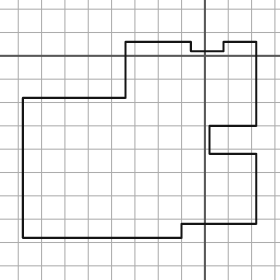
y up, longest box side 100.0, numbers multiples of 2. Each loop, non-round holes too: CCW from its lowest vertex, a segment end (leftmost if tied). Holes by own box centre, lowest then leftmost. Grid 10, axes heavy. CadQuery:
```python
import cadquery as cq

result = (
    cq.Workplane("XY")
    .moveTo(-78.0, -78.0)
    .lineTo(-10.0, -78.0)
    .lineTo(-10.0, -72.0)
    .lineTo(22.0, -72.0)
    .lineTo(22.0, -42.0)
    .lineTo(2.0, -42.0)
    .lineTo(2.0, -30.0)
    .lineTo(22.0, -30.0)
    .lineTo(22.0, 6.0)
    .lineTo(8.0, 6.0)
    .lineTo(8.0, 2.0)
    .lineTo(-6.0, 2.0)
    .lineTo(-6.0, 6.0)
    .lineTo(-34.0, 6.0)
    .lineTo(-34.0, -18.0)
    .lineTo(-78.0, -18.0)
    .close()
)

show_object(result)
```